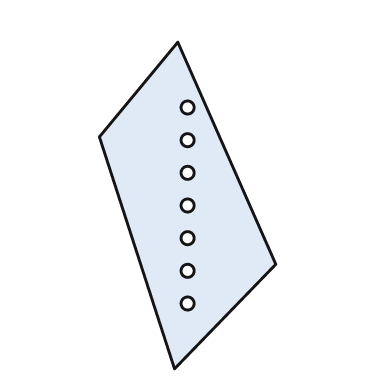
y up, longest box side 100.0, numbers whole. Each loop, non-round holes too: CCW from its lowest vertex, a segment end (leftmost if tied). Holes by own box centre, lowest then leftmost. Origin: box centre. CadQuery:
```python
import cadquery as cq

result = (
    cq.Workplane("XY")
    .moveTo(-4.0, -50.0)
    .lineTo(27.0, -18.0)
    .lineTo(-3.0, 50.0)
    .lineTo(-27.0, 21.0)
    .close()
    .moveTo(0.0, -30.0)
    .circle(2.0)
    .moveTo(0.0, -20.0)
    .circle(2.0)
    .moveTo(0.0, -10.0)
    .circle(2.0)
    .moveTo(0.0, 0.0)
    .circle(2.0)
    .moveTo(0.0, 10.0)
    .circle(2.0)
    .moveTo(0.0, 20.0)
    .circle(2.0)
    .moveTo(0.0, 30.0)
    .circle(2.0)
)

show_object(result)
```